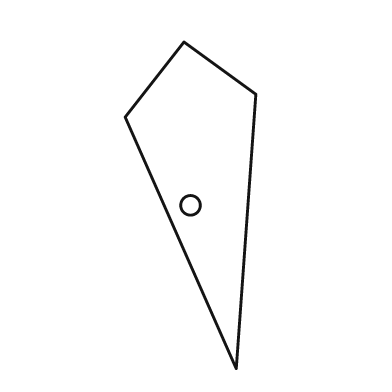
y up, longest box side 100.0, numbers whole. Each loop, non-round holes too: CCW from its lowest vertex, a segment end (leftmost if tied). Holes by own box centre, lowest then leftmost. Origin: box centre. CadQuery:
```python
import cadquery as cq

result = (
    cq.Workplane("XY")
    .moveTo(14.0, -50.0)
    .lineTo(20.0, 34.0)
    .lineTo(-2.0, 50.0)
    .lineTo(-20.0, 27.0)
    .close()
    .moveTo(0.0, 0.0)
    .circle(3.0)
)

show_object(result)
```